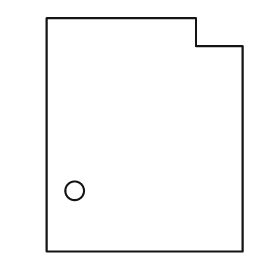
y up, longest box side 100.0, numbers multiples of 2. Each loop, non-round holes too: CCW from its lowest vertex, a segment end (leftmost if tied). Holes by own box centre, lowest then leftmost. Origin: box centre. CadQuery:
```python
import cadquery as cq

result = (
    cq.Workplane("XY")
    .moveTo(-42.0, -50.0)
    .lineTo(42.0, -50.0)
    .lineTo(42.0, 38.0)
    .lineTo(22.0, 38.0)
    .lineTo(22.0, 50.0)
    .lineTo(-42.0, 50.0)
    .close()
    .moveTo(-30.0, -24.0)
    .circle(4.0)
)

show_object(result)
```